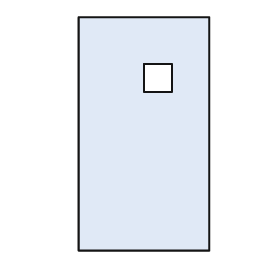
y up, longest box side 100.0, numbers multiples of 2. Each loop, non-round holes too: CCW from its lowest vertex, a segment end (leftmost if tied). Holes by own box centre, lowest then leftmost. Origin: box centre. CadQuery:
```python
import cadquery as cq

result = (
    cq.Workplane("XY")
    .moveTo(-28.0, -50.0)
    .lineTo(28.0, -50.0)
    .lineTo(28.0, 50.0)
    .lineTo(-28.0, 50.0)
    .close()
    .moveTo(0.0, 18.0)
    .lineTo(12.0, 18.0)
    .lineTo(12.0, 30.0)
    .lineTo(0.0, 30.0)
    .close()
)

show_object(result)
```